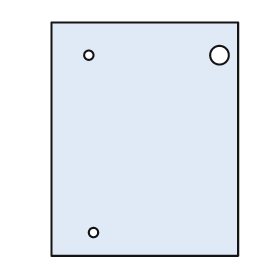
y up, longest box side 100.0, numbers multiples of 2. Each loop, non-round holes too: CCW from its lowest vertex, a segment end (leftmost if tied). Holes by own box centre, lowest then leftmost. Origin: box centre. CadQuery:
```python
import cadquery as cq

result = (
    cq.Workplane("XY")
    .moveTo(-40.0, -50.0)
    .lineTo(40.0, -50.0)
    .lineTo(40.0, 50.0)
    .lineTo(-40.0, 50.0)
    .close()
    .moveTo(-22.0, -40.0)
    .circle(2.0)
    .moveTo(-24.0, 36.0)
    .circle(2.0)
    .moveTo(32.0, 36.0)
    .circle(4.0)
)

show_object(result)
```